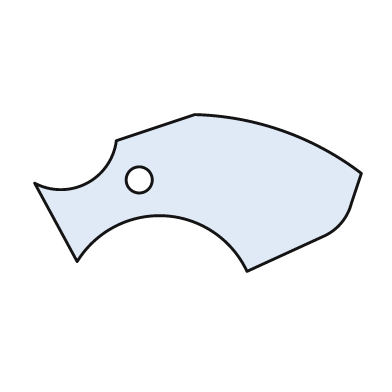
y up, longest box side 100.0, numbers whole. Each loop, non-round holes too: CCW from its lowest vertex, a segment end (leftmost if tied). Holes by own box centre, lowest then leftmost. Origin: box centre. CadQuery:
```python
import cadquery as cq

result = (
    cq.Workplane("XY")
    .moveTo(15.0, -24.0)
    .lineTo(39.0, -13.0)
    .threePointArc((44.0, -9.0), (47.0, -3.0))
    .lineTo(50.0, 6.0)
    .threePointArc((26.0, 19.0), (-1.0, 24.0))
    .lineTo(-25.0, 16.0)
    .threePointArc((-34.0, 3.0), (-50.0, 3.0))
    .lineTo(-37.0, -21.0)
    .threePointArc((-10.0, -7.0), (15.0, -24.0))
    .close()
    .moveTo(-18.0, 4.0)
    .circle(4.0)
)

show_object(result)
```